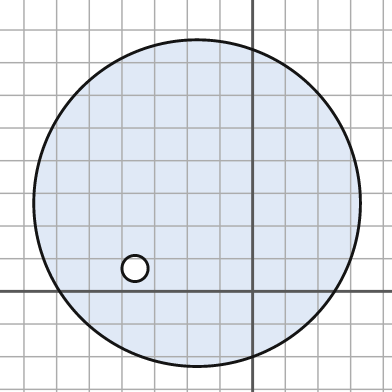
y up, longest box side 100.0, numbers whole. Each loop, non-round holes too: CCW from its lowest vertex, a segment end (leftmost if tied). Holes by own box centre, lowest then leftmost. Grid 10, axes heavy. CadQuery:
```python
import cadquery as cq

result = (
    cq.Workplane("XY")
    .moveTo(-17.0, 27.0)
    .circle(50.0)
    .moveTo(-36.0, 7.0)
    .circle(4.0)
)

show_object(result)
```